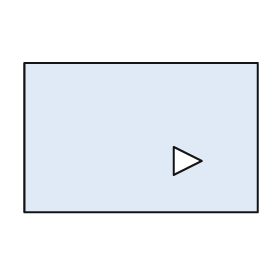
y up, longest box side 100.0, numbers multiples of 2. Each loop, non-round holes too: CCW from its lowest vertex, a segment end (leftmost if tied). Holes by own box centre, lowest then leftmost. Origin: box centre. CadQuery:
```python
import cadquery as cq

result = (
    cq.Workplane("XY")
    .moveTo(-50.0, -32.0)
    .lineTo(50.0, -32.0)
    .lineTo(50.0, 32.0)
    .lineTo(-50.0, 32.0)
    .close()
    .moveTo(14.0, -16.0)
    .lineTo(26.0, -10.0)
    .lineTo(14.0, -4.0)
    .close()
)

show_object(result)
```